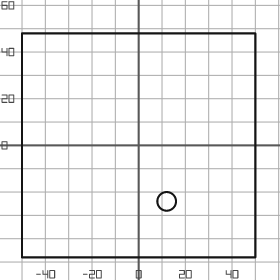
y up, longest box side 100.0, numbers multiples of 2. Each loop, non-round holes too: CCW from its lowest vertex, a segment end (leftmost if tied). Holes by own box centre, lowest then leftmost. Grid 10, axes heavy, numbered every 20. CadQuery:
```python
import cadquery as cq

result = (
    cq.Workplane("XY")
    .moveTo(-50.0, -48.0)
    .lineTo(50.0, -48.0)
    .lineTo(50.0, 48.0)
    .lineTo(-50.0, 48.0)
    .close()
    .moveTo(12.0, -24.0)
    .circle(4.0)
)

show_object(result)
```